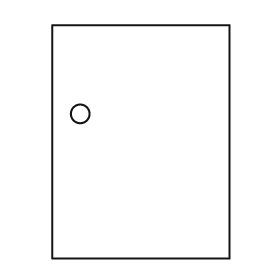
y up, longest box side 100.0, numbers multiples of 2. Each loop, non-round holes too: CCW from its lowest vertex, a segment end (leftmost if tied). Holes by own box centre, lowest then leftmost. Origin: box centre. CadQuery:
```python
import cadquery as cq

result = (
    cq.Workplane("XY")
    .moveTo(-38.0, -50.0)
    .lineTo(38.0, -50.0)
    .lineTo(38.0, 50.0)
    .lineTo(-38.0, 50.0)
    .close()
    .moveTo(-26.0, 12.0)
    .circle(4.0)
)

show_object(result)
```